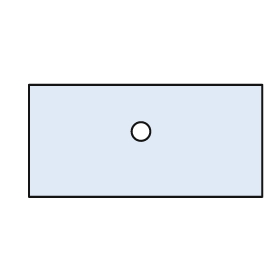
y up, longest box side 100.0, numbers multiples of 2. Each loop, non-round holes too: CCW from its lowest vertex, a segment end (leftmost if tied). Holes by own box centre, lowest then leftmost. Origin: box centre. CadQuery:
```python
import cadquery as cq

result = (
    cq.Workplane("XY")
    .moveTo(-50.0, -24.0)
    .lineTo(50.0, -24.0)
    .lineTo(50.0, 24.0)
    .lineTo(-50.0, 24.0)
    .close()
    .moveTo(-2.0, 4.0)
    .circle(4.0)
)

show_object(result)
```